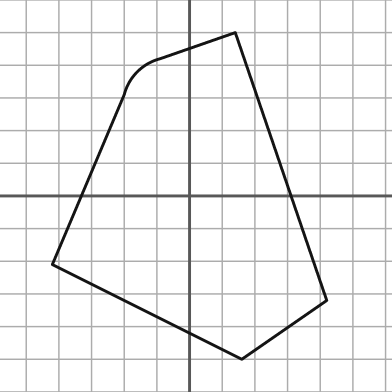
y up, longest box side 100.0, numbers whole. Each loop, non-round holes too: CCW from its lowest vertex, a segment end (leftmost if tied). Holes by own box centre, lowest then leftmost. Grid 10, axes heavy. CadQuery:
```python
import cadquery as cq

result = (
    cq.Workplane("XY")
    .moveTo(16.0, -50.0)
    .lineTo(42.0, -32.0)
    .lineTo(14.0, 50.0)
    .lineTo(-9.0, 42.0)
    .threePointArc((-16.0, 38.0), (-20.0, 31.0))
    .lineTo(-42.0, -21.0)
    .close()
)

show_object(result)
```